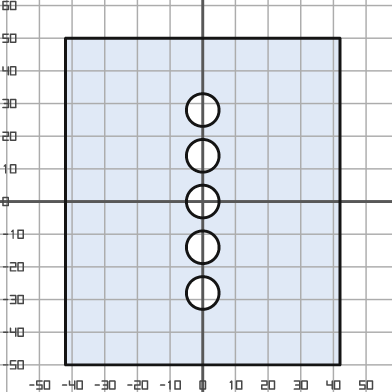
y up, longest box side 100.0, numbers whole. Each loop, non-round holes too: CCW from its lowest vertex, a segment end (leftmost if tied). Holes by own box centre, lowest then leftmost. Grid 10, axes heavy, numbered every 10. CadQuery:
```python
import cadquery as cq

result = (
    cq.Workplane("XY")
    .moveTo(-42.0, -50.0)
    .lineTo(42.0, -50.0)
    .lineTo(42.0, 50.0)
    .lineTo(-42.0, 50.0)
    .close()
    .moveTo(0.0, -28.0)
    .circle(5.0)
    .moveTo(0.0, -14.0)
    .circle(5.0)
    .moveTo(0.0, 0.0)
    .circle(5.0)
    .moveTo(0.0, 14.0)
    .circle(5.0)
    .moveTo(0.0, 28.0)
    .circle(5.0)
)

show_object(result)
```